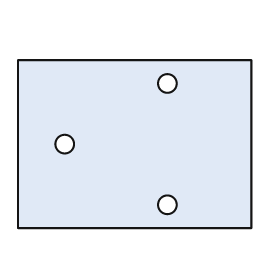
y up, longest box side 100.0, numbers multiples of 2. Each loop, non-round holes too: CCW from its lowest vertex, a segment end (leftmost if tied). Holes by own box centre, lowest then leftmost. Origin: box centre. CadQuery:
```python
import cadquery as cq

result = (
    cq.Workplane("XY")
    .moveTo(-50.0, -36.0)
    .lineTo(50.0, -36.0)
    .lineTo(50.0, 36.0)
    .lineTo(-50.0, 36.0)
    .close()
    .moveTo(14.0, -26.0)
    .circle(4.0)
    .moveTo(-30.0, 0.0)
    .circle(4.0)
    .moveTo(14.0, 26.0)
    .circle(4.0)
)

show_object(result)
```